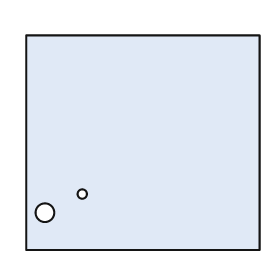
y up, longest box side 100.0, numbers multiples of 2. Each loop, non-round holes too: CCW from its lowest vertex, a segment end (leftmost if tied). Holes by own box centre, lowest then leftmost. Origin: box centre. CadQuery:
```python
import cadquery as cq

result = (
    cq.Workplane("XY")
    .moveTo(-50.0, -46.0)
    .lineTo(50.0, -46.0)
    .lineTo(50.0, 46.0)
    .lineTo(-50.0, 46.0)
    .close()
    .moveTo(-42.0, -30.0)
    .circle(4.0)
    .moveTo(-26.0, -22.0)
    .circle(2.0)
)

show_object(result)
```